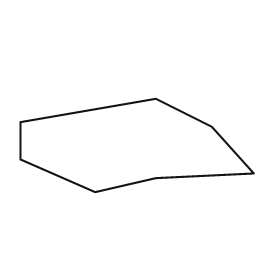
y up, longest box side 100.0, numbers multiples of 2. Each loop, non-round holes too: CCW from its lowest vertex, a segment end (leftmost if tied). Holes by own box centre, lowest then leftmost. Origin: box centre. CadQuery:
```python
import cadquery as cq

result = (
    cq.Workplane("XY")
    .moveTo(-18.0, -20.0)
    .lineTo(8.0, -14.0)
    .lineTo(50.0, -12.0)
    .lineTo(32.0, 8.0)
    .lineTo(8.0, 20.0)
    .lineTo(-50.0, 10.0)
    .lineTo(-50.0, -6.0)
    .close()
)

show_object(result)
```